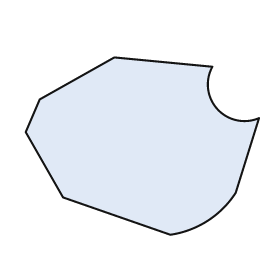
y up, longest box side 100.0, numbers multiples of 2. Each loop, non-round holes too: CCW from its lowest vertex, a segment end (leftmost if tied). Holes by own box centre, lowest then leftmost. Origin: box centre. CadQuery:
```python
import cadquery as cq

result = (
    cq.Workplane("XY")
    .moveTo(12.0, -38.0)
    .threePointArc((28.0, -32.0), (40.0, -20.0))
    .lineTo(50.0, 12.0)
    .threePointArc((32.0, 16.0), (30.0, 34.0))
    .lineTo(-12.0, 38.0)
    .lineTo(-44.0, 20.0)
    .lineTo(-50.0, 6.0)
    .lineTo(-34.0, -22.0)
    .close()
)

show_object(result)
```